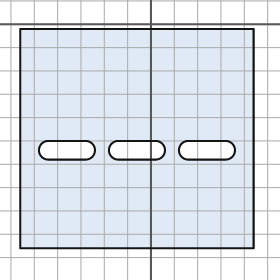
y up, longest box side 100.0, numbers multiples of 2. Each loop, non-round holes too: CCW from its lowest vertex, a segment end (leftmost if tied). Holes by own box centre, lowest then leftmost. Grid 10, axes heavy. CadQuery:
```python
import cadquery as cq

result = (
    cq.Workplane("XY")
    .moveTo(-56.0, -96.0)
    .lineTo(44.0, -96.0)
    .lineTo(44.0, -2.0)
    .lineTo(-56.0, -2.0)
    .close()
    .moveTo(-44.0, -58.0)
    .lineTo(-28.0, -58.0)
    .threePointArc((-24.0, -54.0), (-28.0, -50.0))
    .lineTo(-44.0, -50.0)
    .threePointArc((-48.0, -54.0), (-44.0, -58.0))
    .close()
    .moveTo(-14.0, -58.0)
    .lineTo(2.0, -58.0)
    .threePointArc((6.0, -54.0), (2.0, -50.0))
    .lineTo(-14.0, -50.0)
    .threePointArc((-18.0, -54.0), (-14.0, -58.0))
    .close()
    .moveTo(16.0, -58.0)
    .lineTo(32.0, -58.0)
    .threePointArc((36.0, -54.0), (32.0, -50.0))
    .lineTo(16.0, -50.0)
    .threePointArc((12.0, -54.0), (16.0, -58.0))
    .close()
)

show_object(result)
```